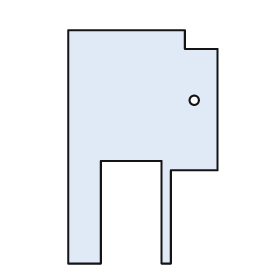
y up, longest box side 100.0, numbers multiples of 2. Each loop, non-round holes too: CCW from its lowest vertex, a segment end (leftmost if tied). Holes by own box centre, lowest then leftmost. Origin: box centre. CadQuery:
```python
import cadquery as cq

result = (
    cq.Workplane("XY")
    .moveTo(-32.0, -50.0)
    .lineTo(-18.0, -50.0)
    .lineTo(-18.0, -6.0)
    .lineTo(8.0, -6.0)
    .lineTo(8.0, -50.0)
    .lineTo(12.0, -50.0)
    .lineTo(12.0, -10.0)
    .lineTo(32.0, -10.0)
    .lineTo(32.0, 42.0)
    .lineTo(18.0, 42.0)
    .lineTo(18.0, 50.0)
    .lineTo(-32.0, 50.0)
    .close()
    .moveTo(22.0, 20.0)
    .circle(2.0)
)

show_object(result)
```